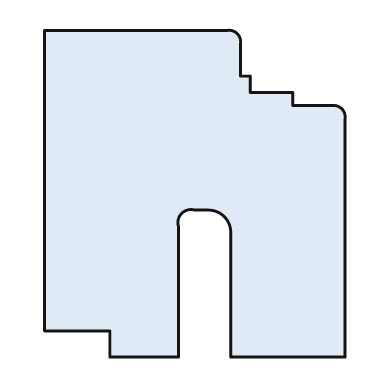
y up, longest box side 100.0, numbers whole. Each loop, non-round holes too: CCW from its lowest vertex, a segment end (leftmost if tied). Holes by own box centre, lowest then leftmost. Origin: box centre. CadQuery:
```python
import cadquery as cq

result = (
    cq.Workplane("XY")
    .moveTo(-26.0, -50.0)
    .lineTo(-5.0, -50.0)
    .lineTo(-5.0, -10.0)
    .threePointArc((-4.0, -6.0), (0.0, -5.0))
    .lineTo(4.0, -5.0)
    .threePointArc((9.0, -7.0), (11.0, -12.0))
    .lineTo(11.0, -50.0)
    .lineTo(46.0, -50.0)
    .lineTo(46.0, 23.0)
    .threePointArc((45.0, 26.0), (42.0, 27.0))
    .lineTo(30.0, 27.0)
    .lineTo(30.0, 31.0)
    .lineTo(17.0, 31.0)
    .lineTo(17.0, 36.0)
    .lineTo(14.0, 36.0)
    .lineTo(14.0, 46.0)
    .threePointArc((13.0, 49.0), (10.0, 50.0))
    .lineTo(-46.0, 50.0)
    .lineTo(-46.0, -42.0)
    .lineTo(-26.0, -42.0)
    .close()
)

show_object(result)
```